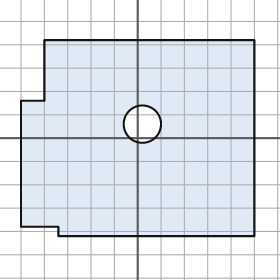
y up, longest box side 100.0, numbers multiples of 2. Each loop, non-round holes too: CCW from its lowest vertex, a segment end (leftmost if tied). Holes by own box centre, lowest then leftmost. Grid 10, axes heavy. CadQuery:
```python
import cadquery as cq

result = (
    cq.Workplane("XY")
    .moveTo(-34.0, -42.0)
    .lineTo(50.0, -42.0)
    .lineTo(50.0, 42.0)
    .lineTo(-40.0, 42.0)
    .lineTo(-40.0, 16.0)
    .lineTo(-50.0, 16.0)
    .lineTo(-50.0, -38.0)
    .lineTo(-34.0, -38.0)
    .close()
    .moveTo(2.0, 6.0)
    .circle(8.0)
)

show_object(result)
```